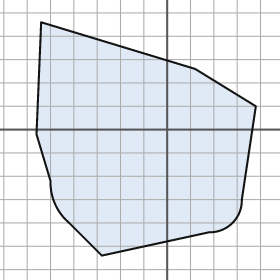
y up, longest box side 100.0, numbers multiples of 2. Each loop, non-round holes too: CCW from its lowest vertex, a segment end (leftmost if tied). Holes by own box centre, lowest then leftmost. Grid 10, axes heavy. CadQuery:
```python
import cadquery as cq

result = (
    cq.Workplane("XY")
    .moveTo(-28.0, -54.0)
    .lineTo(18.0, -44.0)
    .threePointArc((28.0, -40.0), (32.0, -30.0))
    .lineTo(38.0, 10.0)
    .lineTo(12.0, 26.0)
    .lineTo(-54.0, 46.0)
    .lineTo(-56.0, -2.0)
    .lineTo(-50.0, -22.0)
    .threePointArc((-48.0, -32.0), (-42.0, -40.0))
    .close()
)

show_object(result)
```